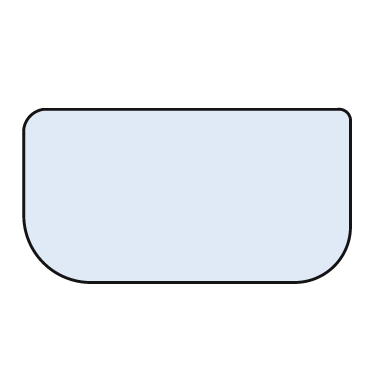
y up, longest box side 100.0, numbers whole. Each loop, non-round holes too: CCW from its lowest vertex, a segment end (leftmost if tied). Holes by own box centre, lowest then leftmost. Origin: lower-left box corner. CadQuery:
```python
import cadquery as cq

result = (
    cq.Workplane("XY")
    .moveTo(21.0, 0.0)
    .lineTo(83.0, 0.0)
    .threePointArc((95.0, 5.0), (100.0, 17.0))
    .lineTo(100.0, 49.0)
    .threePointArc((99.0, 52.0), (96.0, 53.0))
    .lineTo(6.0, 53.0)
    .threePointArc((2.0, 51.0), (0.0, 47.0))
    .lineTo(0.0, 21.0)
    .threePointArc((6.0, 6.0), (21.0, 0.0))
    .close()
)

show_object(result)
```